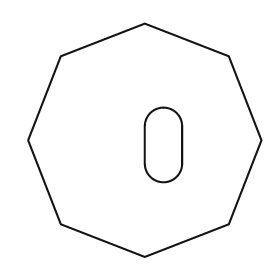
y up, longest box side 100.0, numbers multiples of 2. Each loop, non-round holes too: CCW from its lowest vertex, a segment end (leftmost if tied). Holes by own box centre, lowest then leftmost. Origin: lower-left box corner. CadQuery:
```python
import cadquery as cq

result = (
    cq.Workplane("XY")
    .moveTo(50.0, 0.0)
    .lineTo(86.0, 14.0)
    .lineTo(100.0, 50.0)
    .lineTo(86.0, 86.0)
    .lineTo(50.0, 100.0)
    .lineTo(14.0, 86.0)
    .lineTo(0.0, 50.0)
    .lineTo(14.0, 14.0)
    .close()
    .moveTo(50.0, 40.0)
    .threePointArc((58.0, 32.0), (66.0, 40.0))
    .lineTo(66.0, 56.0)
    .threePointArc((58.0, 64.0), (50.0, 56.0))
    .close()
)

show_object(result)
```